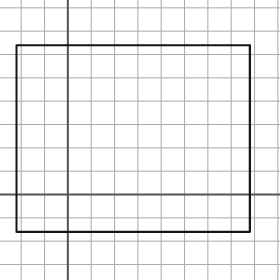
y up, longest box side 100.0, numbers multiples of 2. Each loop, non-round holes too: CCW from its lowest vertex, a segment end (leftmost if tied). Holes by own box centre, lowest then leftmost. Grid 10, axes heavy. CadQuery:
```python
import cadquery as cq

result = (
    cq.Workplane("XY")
    .moveTo(-22.0, -16.0)
    .lineTo(78.0, -16.0)
    .lineTo(78.0, 64.0)
    .lineTo(-22.0, 64.0)
    .close()
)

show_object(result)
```